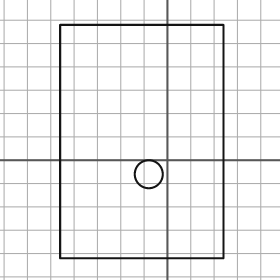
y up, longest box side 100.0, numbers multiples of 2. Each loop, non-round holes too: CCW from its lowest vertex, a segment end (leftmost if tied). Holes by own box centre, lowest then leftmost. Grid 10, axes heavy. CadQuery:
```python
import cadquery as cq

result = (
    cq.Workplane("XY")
    .moveTo(-46.0, -42.0)
    .lineTo(24.0, -42.0)
    .lineTo(24.0, 58.0)
    .lineTo(-46.0, 58.0)
    .close()
    .moveTo(-8.0, -6.0)
    .circle(6.0)
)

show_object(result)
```